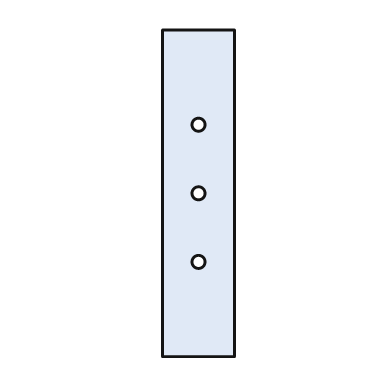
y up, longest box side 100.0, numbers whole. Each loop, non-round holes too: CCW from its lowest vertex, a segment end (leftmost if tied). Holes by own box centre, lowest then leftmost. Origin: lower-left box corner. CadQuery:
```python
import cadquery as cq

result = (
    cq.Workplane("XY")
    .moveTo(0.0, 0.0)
    .lineTo(22.0, 0.0)
    .lineTo(22.0, 100.0)
    .lineTo(0.0, 100.0)
    .close()
    .moveTo(11.0, 29.0)
    .circle(2.0)
    .moveTo(11.0, 50.0)
    .circle(2.0)
    .moveTo(11.0, 71.0)
    .circle(2.0)
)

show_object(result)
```